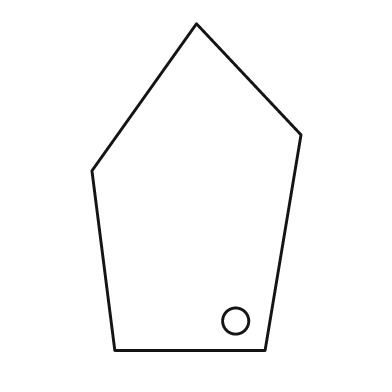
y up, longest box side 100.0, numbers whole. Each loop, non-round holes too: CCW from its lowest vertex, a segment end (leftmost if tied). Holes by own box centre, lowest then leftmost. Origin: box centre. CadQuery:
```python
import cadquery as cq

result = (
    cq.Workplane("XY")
    .moveTo(-25.0, -50.0)
    .lineTo(21.0, -50.0)
    .lineTo(32.0, 16.0)
    .lineTo(0.0, 50.0)
    .lineTo(-32.0, 5.0)
    .close()
    .moveTo(12.0, -41.0)
    .circle(4.0)
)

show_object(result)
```